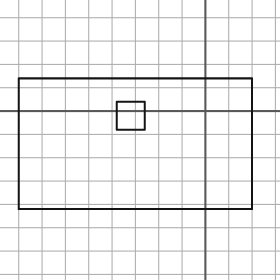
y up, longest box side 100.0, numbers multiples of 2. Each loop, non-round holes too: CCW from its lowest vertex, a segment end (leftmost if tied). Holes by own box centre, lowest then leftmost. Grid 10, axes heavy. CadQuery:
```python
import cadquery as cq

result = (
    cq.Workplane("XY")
    .moveTo(-80.0, -42.0)
    .lineTo(20.0, -42.0)
    .lineTo(20.0, 14.0)
    .lineTo(-80.0, 14.0)
    .close()
    .moveTo(-38.0, -8.0)
    .lineTo(-26.0, -8.0)
    .lineTo(-26.0, 4.0)
    .lineTo(-38.0, 4.0)
    .close()
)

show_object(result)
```